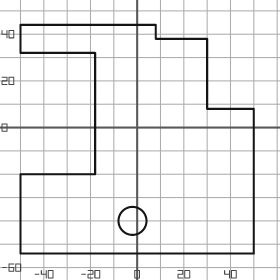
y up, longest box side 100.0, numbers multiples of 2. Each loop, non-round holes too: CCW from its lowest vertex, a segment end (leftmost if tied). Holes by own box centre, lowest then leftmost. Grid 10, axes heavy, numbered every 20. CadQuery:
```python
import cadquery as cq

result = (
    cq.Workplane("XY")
    .moveTo(-50.0, -54.0)
    .lineTo(50.0, -54.0)
    .lineTo(50.0, 8.0)
    .lineTo(30.0, 8.0)
    .lineTo(30.0, 38.0)
    .lineTo(8.0, 38.0)
    .lineTo(8.0, 44.0)
    .lineTo(-50.0, 44.0)
    .lineTo(-50.0, 32.0)
    .lineTo(-18.0, 32.0)
    .lineTo(-18.0, -20.0)
    .lineTo(-50.0, -20.0)
    .close()
    .moveTo(-2.0, -40.0)
    .circle(6.0)
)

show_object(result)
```